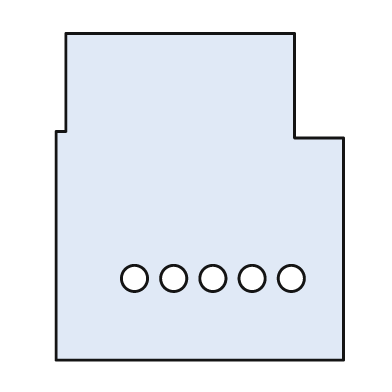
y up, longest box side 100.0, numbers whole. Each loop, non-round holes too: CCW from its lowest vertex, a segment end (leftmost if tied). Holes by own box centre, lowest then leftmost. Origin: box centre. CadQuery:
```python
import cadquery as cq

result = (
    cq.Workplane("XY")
    .moveTo(-44.0, -50.0)
    .lineTo(44.0, -50.0)
    .lineTo(44.0, 18.0)
    .lineTo(29.0, 18.0)
    .lineTo(29.0, 50.0)
    .lineTo(-41.0, 50.0)
    .lineTo(-41.0, 20.0)
    .lineTo(-44.0, 20.0)
    .close()
    .moveTo(-20.0, -25.0)
    .circle(4.0)
    .moveTo(-8.0, -25.0)
    .circle(4.0)
    .moveTo(4.0, -25.0)
    .circle(4.0)
    .moveTo(16.0, -25.0)
    .circle(4.0)
    .moveTo(28.0, -25.0)
    .circle(4.0)
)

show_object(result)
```